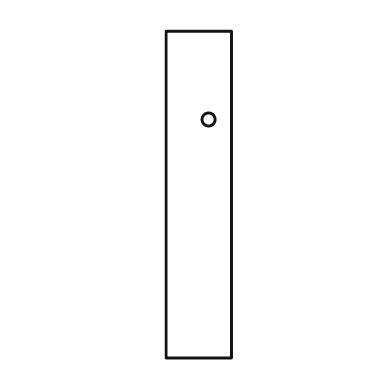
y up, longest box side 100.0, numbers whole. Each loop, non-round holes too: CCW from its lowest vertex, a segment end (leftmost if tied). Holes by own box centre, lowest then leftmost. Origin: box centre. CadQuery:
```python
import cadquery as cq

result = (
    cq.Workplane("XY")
    .moveTo(-10.0, -50.0)
    .lineTo(10.0, -50.0)
    .lineTo(10.0, 50.0)
    .lineTo(-10.0, 50.0)
    .close()
    .moveTo(3.0, 23.0)
    .circle(2.0)
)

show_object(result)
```